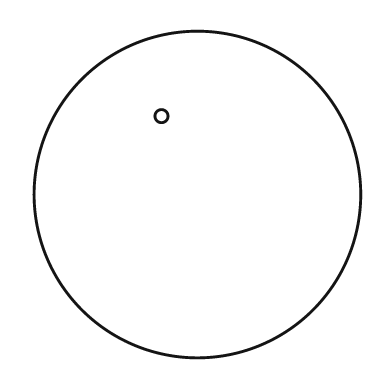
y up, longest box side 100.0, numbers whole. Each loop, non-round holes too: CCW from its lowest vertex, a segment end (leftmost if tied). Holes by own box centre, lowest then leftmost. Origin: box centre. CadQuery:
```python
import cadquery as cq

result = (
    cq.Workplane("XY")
    .moveTo(0.0, 0.0)
    .circle(50.0)
    .moveTo(-11.0, 24.0)
    .circle(2.0)
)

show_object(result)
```